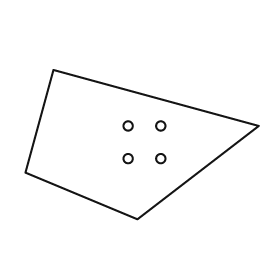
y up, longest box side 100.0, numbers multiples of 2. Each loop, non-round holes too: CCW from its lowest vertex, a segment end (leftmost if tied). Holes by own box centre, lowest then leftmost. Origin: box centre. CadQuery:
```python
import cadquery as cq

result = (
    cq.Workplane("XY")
    .moveTo(-2.0, -32.0)
    .lineTo(50.0, 8.0)
    .lineTo(-38.0, 32.0)
    .lineTo(-50.0, -12.0)
    .close()
    .moveTo(-6.0, -6.0)
    .circle(2.0)
    .moveTo(8.0, -6.0)
    .circle(2.0)
    .moveTo(-6.0, 8.0)
    .circle(2.0)
    .moveTo(8.0, 8.0)
    .circle(2.0)
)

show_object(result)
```